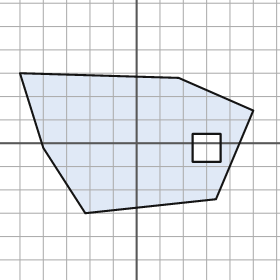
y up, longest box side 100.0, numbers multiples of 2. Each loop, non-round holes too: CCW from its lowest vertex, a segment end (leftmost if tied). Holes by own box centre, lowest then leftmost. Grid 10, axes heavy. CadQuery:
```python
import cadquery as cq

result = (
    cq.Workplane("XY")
    .moveTo(-22.0, -30.0)
    .lineTo(34.0, -24.0)
    .lineTo(50.0, 14.0)
    .lineTo(18.0, 28.0)
    .lineTo(-50.0, 30.0)
    .lineTo(-40.0, -2.0)
    .close()
    .moveTo(24.0, -8.0)
    .lineTo(36.0, -8.0)
    .lineTo(36.0, 4.0)
    .lineTo(24.0, 4.0)
    .close()
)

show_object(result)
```